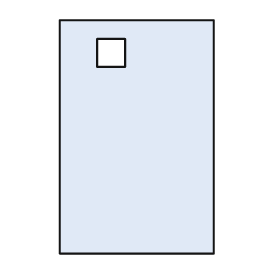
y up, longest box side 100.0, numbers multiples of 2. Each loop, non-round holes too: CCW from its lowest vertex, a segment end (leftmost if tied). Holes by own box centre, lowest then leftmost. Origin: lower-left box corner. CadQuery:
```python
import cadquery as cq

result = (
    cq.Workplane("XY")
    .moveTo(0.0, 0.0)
    .lineTo(66.0, 0.0)
    .lineTo(66.0, 100.0)
    .lineTo(0.0, 100.0)
    .close()
    .moveTo(16.0, 80.0)
    .lineTo(28.0, 80.0)
    .lineTo(28.0, 92.0)
    .lineTo(16.0, 92.0)
    .close()
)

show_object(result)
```